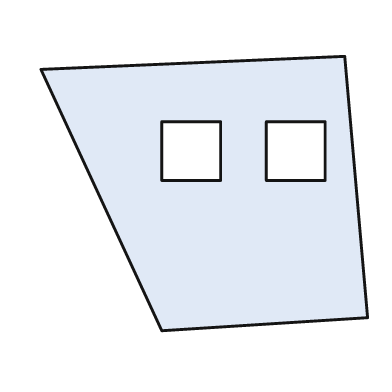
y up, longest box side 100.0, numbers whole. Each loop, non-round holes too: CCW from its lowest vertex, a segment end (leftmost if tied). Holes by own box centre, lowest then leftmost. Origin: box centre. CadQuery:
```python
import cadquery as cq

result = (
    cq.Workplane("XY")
    .moveTo(-13.0, -42.0)
    .lineTo(50.0, -38.0)
    .lineTo(43.0, 42.0)
    .lineTo(-50.0, 38.0)
    .close()
    .moveTo(-13.0, 4.0)
    .lineTo(5.0, 4.0)
    .lineTo(5.0, 22.0)
    .lineTo(-13.0, 22.0)
    .close()
    .moveTo(19.0, 4.0)
    .lineTo(37.0, 4.0)
    .lineTo(37.0, 22.0)
    .lineTo(19.0, 22.0)
    .close()
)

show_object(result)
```